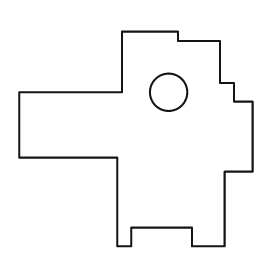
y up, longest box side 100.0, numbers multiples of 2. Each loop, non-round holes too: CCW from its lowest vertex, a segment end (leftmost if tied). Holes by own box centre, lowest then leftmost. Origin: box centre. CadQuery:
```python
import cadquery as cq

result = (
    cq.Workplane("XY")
    .moveTo(-8.0, -46.0)
    .lineTo(-2.0, -46.0)
    .lineTo(-2.0, -38.0)
    .lineTo(24.0, -38.0)
    .lineTo(24.0, -46.0)
    .lineTo(38.0, -46.0)
    .lineTo(38.0, -14.0)
    .lineTo(50.0, -14.0)
    .lineTo(50.0, 16.0)
    .lineTo(42.0, 16.0)
    .lineTo(42.0, 24.0)
    .lineTo(36.0, 24.0)
    .lineTo(36.0, 42.0)
    .lineTo(18.0, 42.0)
    .lineTo(18.0, 46.0)
    .lineTo(-6.0, 46.0)
    .lineTo(-6.0, 20.0)
    .lineTo(-50.0, 20.0)
    .lineTo(-50.0, -8.0)
    .lineTo(-8.0, -8.0)
    .close()
    .moveTo(14.0, 20.0)
    .circle(8.0)
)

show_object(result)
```